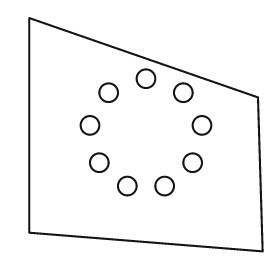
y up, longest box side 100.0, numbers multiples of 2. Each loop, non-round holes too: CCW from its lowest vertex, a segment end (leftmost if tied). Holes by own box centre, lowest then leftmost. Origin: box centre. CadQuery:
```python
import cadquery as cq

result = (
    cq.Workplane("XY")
    .moveTo(50.0, -50.0)
    .lineTo(48.0, 16.0)
    .lineTo(-50.0, 50.0)
    .lineTo(-50.0, -42.0)
    .close()
    .moveTo(-8.0, -22.0)
    .circle(4.0)
    .moveTo(8.0, -22.0)
    .circle(4.0)
    .moveTo(-20.0, -12.0)
    .circle(4.0)
    .moveTo(20.0, -12.0)
    .circle(4.0)
    .moveTo(-24.0, 4.0)
    .circle(4.0)
    .moveTo(24.0, 4.0)
    .circle(4.0)
    .moveTo(-16.0, 18.0)
    .circle(4.0)
    .moveTo(16.0, 18.0)
    .circle(4.0)
    .moveTo(0.0, 24.0)
    .circle(4.0)
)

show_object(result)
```